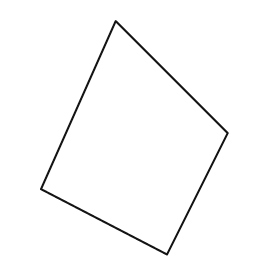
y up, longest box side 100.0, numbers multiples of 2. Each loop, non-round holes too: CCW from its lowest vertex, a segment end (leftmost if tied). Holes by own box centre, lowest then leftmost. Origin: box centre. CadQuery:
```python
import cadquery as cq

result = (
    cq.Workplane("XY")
    .moveTo(14.0, -50.0)
    .lineTo(40.0, 2.0)
    .lineTo(-8.0, 50.0)
    .lineTo(-40.0, -22.0)
    .close()
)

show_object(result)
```